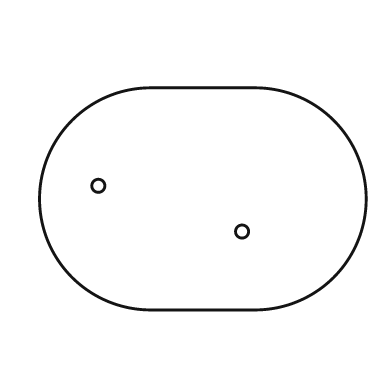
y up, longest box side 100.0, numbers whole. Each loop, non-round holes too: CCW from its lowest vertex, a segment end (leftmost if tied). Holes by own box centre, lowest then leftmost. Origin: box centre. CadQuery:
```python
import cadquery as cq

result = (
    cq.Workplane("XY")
    .moveTo(-16.0, -34.0)
    .lineTo(16.0, -34.0)
    .threePointArc((50.0, 0.0), (16.0, 34.0))
    .lineTo(-16.0, 34.0)
    .threePointArc((-50.0, 0.0), (-16.0, -34.0))
    .close()
    .moveTo(12.0, -10.0)
    .circle(2.0)
    .moveTo(-32.0, 4.0)
    .circle(2.0)
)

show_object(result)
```